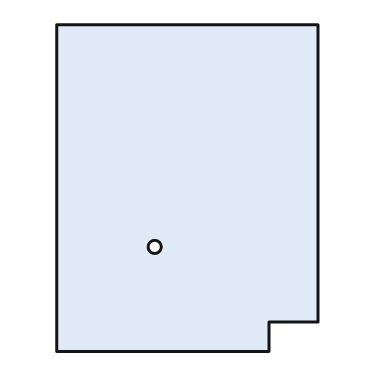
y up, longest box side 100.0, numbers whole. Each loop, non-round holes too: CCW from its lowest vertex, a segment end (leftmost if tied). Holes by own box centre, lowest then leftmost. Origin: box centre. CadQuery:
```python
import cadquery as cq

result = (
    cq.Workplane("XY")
    .moveTo(-40.0, -50.0)
    .lineTo(25.0, -50.0)
    .lineTo(25.0, -41.0)
    .lineTo(40.0, -41.0)
    .lineTo(40.0, 50.0)
    .lineTo(-40.0, 50.0)
    .close()
    .moveTo(-10.0, -18.0)
    .circle(2.0)
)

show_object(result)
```